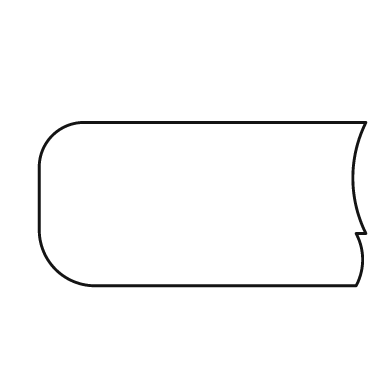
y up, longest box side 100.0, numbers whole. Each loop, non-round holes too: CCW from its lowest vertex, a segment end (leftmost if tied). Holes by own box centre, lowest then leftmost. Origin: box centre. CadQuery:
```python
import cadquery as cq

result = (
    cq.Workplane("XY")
    .moveTo(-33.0, -25.0)
    .lineTo(47.0, -25.0)
    .threePointArc((49.0, -17.0), (47.0, -9.0))
    .lineTo(50.0, -9.0)
    .threePointArc((46.0, 8.0), (50.0, 25.0))
    .lineTo(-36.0, 25.0)
    .threePointArc((-46.0, 21.0), (-50.0, 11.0))
    .lineTo(-50.0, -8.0)
    .threePointArc((-45.0, -20.0), (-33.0, -25.0))
    .close()
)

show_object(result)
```